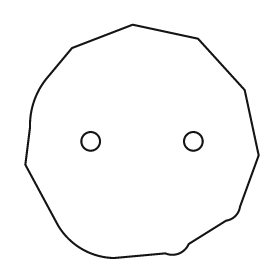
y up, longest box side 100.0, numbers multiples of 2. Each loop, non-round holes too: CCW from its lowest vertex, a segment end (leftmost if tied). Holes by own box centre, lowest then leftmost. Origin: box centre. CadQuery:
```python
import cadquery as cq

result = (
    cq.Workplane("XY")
    .moveTo(-12.0, -50.0)
    .lineTo(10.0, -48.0)
    .threePointArc((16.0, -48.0), (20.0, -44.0))
    .lineTo(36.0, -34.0)
    .threePointArc((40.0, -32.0), (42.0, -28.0))
    .lineTo(50.0, -6.0)
    .lineTo(44.0, 22.0)
    .lineTo(24.0, 44.0)
    .lineTo(-4.0, 50.0)
    .lineTo(-30.0, 40.0)
    .lineTo(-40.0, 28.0)
    .threePointArc((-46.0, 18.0), (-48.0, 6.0))
    .lineTo(-50.0, -10.0)
    .lineTo(-36.0, -36.0)
    .threePointArc((-26.0, -46.0), (-12.0, -50.0))
    .close()
    .moveTo(-22.0, 0.0)
    .circle(4.0)
    .moveTo(22.0, 0.0)
    .circle(4.0)
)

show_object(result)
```